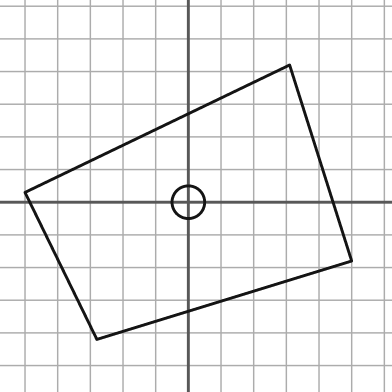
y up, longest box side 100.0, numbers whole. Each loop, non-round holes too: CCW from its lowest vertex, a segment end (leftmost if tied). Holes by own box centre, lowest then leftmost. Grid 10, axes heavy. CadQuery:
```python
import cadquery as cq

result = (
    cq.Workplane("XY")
    .moveTo(-28.0, -42.0)
    .lineTo(50.0, -18.0)
    .lineTo(31.0, 42.0)
    .lineTo(-50.0, 3.0)
    .close()
    .moveTo(0.0, 0.0)
    .circle(5.0)
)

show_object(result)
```